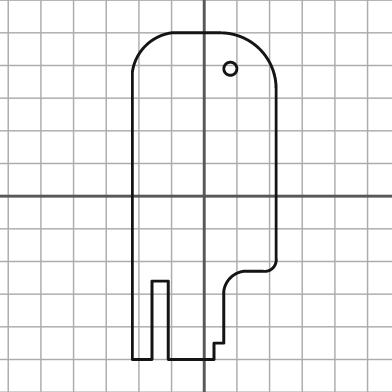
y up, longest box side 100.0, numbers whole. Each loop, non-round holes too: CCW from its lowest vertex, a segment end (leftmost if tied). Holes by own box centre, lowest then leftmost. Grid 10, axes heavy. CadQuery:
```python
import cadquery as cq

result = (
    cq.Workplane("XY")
    .moveTo(-22.0, -50.0)
    .lineTo(-16.0, -50.0)
    .lineTo(-16.0, -26.0)
    .lineTo(-11.0, -26.0)
    .lineTo(-11.0, -50.0)
    .lineTo(3.0, -50.0)
    .lineTo(3.0, -45.0)
    .lineTo(6.0, -45.0)
    .lineTo(6.0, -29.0)
    .threePointArc((8.0, -25.0), (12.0, -23.0))
    .lineTo(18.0, -23.0)
    .threePointArc((21.0, -22.0), (22.0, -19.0))
    .lineTo(22.0, 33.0)
    .threePointArc((17.0, 45.0), (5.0, 50.0))
    .lineTo(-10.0, 50.0)
    .threePointArc((-18.0, 46.0), (-22.0, 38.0))
    .close()
    .moveTo(8.0, 39.0)
    .circle(2.0)
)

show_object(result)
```